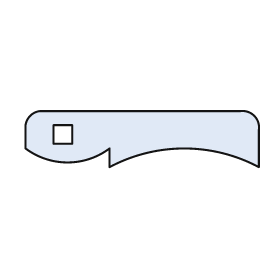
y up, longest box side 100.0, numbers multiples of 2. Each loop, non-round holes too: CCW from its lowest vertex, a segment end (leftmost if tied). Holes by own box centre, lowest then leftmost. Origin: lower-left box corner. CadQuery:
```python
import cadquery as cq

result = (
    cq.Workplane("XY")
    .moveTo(36.0, 0.0)
    .threePointArc((68.0, 8.0), (100.0, 0.0))
    .lineTo(100.0, 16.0)
    .threePointArc((98.0, 22.0), (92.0, 24.0))
    .lineTo(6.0, 24.0)
    .threePointArc((2.0, 22.0), (0.0, 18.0))
    .lineTo(0.0, 8.0)
    .threePointArc((18.0, 2.0), (36.0, 8.0))
    .close()
    .moveTo(12.0, 10.0)
    .lineTo(20.0, 10.0)
    .lineTo(20.0, 18.0)
    .lineTo(12.0, 18.0)
    .close()
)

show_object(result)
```